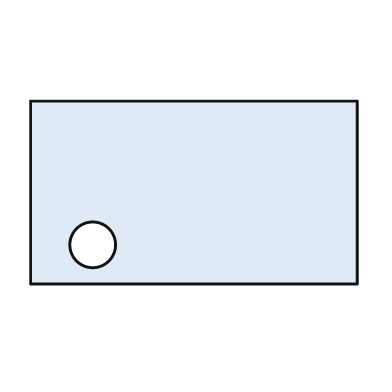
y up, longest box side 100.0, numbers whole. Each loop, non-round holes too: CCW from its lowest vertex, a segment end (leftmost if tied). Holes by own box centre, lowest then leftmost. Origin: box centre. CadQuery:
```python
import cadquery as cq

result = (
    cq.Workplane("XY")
    .moveTo(-50.0, -28.0)
    .lineTo(50.0, -28.0)
    .lineTo(50.0, 28.0)
    .lineTo(-50.0, 28.0)
    .close()
    .moveTo(-31.0, -16.0)
    .circle(7.0)
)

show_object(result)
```